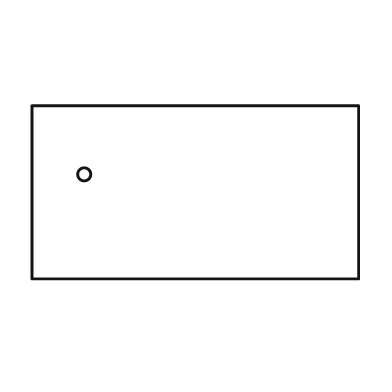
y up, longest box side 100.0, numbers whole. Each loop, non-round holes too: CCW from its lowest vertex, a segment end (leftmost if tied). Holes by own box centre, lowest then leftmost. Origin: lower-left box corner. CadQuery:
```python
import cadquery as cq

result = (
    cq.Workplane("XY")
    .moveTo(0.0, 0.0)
    .lineTo(100.0, 0.0)
    .lineTo(100.0, 53.0)
    .lineTo(0.0, 53.0)
    .close()
    .moveTo(16.0, 32.0)
    .circle(2.0)
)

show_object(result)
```